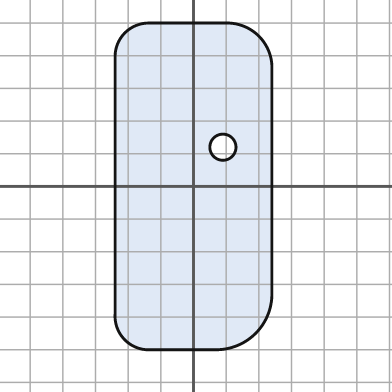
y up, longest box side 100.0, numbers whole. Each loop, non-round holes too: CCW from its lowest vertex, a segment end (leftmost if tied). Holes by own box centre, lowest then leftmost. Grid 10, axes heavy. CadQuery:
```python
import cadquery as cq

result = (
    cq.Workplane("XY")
    .moveTo(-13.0, -50.0)
    .lineTo(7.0, -50.0)
    .threePointArc((19.0, -45.0), (24.0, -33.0))
    .lineTo(24.0, 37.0)
    .threePointArc((20.0, 46.0), (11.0, 50.0))
    .lineTo(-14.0, 50.0)
    .threePointArc((-21.0, 47.0), (-24.0, 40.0))
    .lineTo(-24.0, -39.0)
    .threePointArc((-21.0, -47.0), (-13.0, -50.0))
    .close()
    .moveTo(9.0, 12.0)
    .circle(4.0)
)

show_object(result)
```